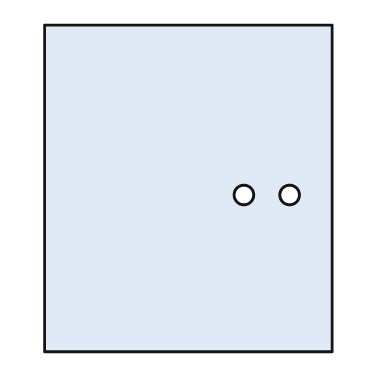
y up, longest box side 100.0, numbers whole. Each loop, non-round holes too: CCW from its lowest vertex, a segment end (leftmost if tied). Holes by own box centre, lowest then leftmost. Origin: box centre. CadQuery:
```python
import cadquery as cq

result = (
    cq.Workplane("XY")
    .moveTo(-44.0, -50.0)
    .lineTo(44.0, -50.0)
    .lineTo(44.0, 50.0)
    .lineTo(-44.0, 50.0)
    .close()
    .moveTo(17.0, -2.0)
    .circle(3.0)
    .moveTo(31.0, -2.0)
    .circle(3.0)
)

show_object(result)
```